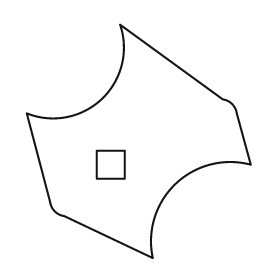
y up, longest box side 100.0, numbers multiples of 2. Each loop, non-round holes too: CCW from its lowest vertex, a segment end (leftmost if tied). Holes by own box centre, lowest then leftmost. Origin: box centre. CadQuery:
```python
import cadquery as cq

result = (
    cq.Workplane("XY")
    .moveTo(6.0, -50.0)
    .threePointArc((16.0, -18.0), (48.0, -10.0))
    .lineTo(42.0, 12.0)
    .threePointArc((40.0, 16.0), (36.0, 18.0))
    .lineTo(-8.0, 50.0)
    .threePointArc((-16.0, 18.0), (-48.0, 12.0))
    .lineTo(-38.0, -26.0)
    .threePointArc((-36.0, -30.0), (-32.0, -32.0))
    .close()
    .moveTo(-18.0, -16.0)
    .lineTo(-6.0, -16.0)
    .lineTo(-6.0, -4.0)
    .lineTo(-18.0, -4.0)
    .close()
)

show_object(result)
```